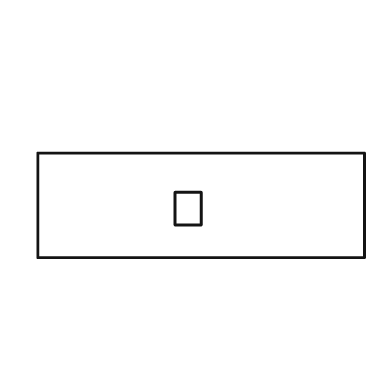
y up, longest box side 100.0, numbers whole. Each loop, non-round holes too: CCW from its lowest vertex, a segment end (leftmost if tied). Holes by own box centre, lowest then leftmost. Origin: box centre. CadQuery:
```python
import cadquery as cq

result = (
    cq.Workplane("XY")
    .moveTo(-50.0, -16.0)
    .lineTo(50.0, -16.0)
    .lineTo(50.0, 16.0)
    .lineTo(-50.0, 16.0)
    .close()
    .moveTo(-8.0, -6.0)
    .lineTo(0.0, -6.0)
    .lineTo(0.0, 4.0)
    .lineTo(-8.0, 4.0)
    .close()
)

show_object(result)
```